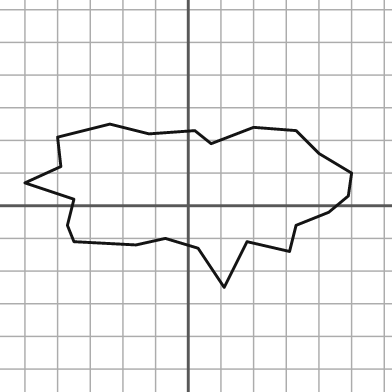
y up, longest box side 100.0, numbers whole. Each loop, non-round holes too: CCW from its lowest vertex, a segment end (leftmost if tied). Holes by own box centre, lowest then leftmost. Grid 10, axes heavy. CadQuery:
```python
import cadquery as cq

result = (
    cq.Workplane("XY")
    .moveTo(11.0, -25.0)
    .lineTo(18.0, -11.0)
    .lineTo(31.0, -14.0)
    .lineTo(33.0, -6.0)
    .lineTo(43.0, -2.0)
    .lineTo(49.0, 3.0)
    .lineTo(50.0, 10.0)
    .lineTo(40.0, 16.0)
    .lineTo(33.0, 23.0)
    .lineTo(20.0, 24.0)
    .lineTo(7.0, 19.0)
    .lineTo(2.0, 23.0)
    .lineTo(-12.0, 22.0)
    .lineTo(-24.0, 25.0)
    .lineTo(-40.0, 21.0)
    .lineTo(-39.0, 12.0)
    .lineTo(-50.0, 7.0)
    .lineTo(-35.0, 2.0)
    .lineTo(-37.0, -6.0)
    .lineTo(-35.0, -11.0)
    .lineTo(-16.0, -12.0)
    .lineTo(-7.0, -10.0)
    .lineTo(3.0, -13.0)
    .close()
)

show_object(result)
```